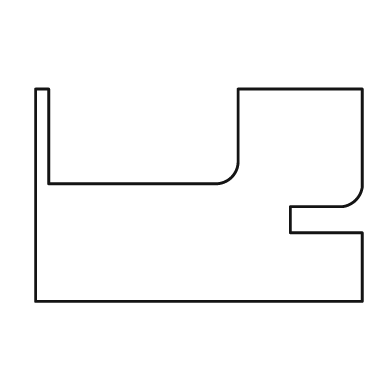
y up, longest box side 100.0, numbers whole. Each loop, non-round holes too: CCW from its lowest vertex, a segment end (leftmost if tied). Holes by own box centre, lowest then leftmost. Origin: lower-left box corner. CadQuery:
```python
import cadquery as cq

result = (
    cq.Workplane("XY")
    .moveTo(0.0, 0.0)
    .lineTo(100.0, 0.0)
    .lineTo(100.0, 21.0)
    .lineTo(78.0, 21.0)
    .lineTo(78.0, 29.0)
    .lineTo(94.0, 29.0)
    .threePointArc((98.0, 31.0), (100.0, 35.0))
    .lineTo(100.0, 65.0)
    .lineTo(62.0, 65.0)
    .lineTo(62.0, 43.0)
    .threePointArc((60.0, 38.0), (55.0, 36.0))
    .lineTo(4.0, 36.0)
    .lineTo(4.0, 65.0)
    .lineTo(0.0, 65.0)
    .close()
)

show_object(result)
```